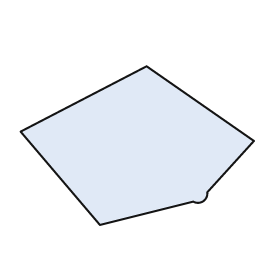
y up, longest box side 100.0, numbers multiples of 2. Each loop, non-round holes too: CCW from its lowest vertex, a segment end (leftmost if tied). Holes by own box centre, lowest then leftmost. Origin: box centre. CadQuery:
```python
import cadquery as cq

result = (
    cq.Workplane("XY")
    .moveTo(-16.0, -34.0)
    .lineTo(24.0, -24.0)
    .threePointArc((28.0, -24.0), (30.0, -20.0))
    .lineTo(50.0, 2.0)
    .lineTo(4.0, 34.0)
    .lineTo(-50.0, 6.0)
    .close()
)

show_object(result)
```